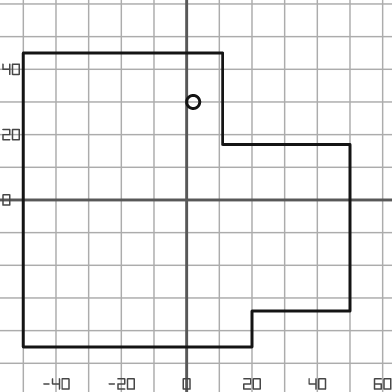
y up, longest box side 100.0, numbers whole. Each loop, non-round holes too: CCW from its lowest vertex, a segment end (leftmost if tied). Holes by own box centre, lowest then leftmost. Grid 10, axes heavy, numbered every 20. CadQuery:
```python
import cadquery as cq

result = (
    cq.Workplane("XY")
    .moveTo(-50.0, -45.0)
    .lineTo(20.0, -45.0)
    .lineTo(20.0, -34.0)
    .lineTo(50.0, -34.0)
    .lineTo(50.0, 17.0)
    .lineTo(11.0, 17.0)
    .lineTo(11.0, 45.0)
    .lineTo(-50.0, 45.0)
    .close()
    .moveTo(2.0, 30.0)
    .circle(2.0)
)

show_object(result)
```